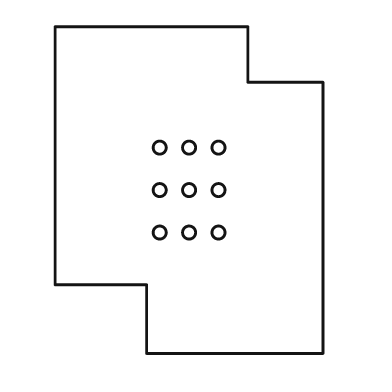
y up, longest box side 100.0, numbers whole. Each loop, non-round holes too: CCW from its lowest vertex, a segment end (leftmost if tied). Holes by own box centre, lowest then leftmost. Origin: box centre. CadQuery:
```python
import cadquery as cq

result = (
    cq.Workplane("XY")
    .moveTo(-13.0, -50.0)
    .lineTo(41.0, -50.0)
    .lineTo(41.0, 33.0)
    .lineTo(18.0, 33.0)
    .lineTo(18.0, 50.0)
    .lineTo(-41.0, 50.0)
    .lineTo(-41.0, -29.0)
    .lineTo(-13.0, -29.0)
    .close()
    .moveTo(-9.0, -13.0)
    .circle(2.0)
    .moveTo(0.0, -13.0)
    .circle(2.0)
    .moveTo(9.0, -13.0)
    .circle(2.0)
    .moveTo(-9.0, 0.0)
    .circle(2.0)
    .moveTo(0.0, 0.0)
    .circle(2.0)
    .moveTo(9.0, 0.0)
    .circle(2.0)
    .moveTo(-9.0, 13.0)
    .circle(2.0)
    .moveTo(0.0, 13.0)
    .circle(2.0)
    .moveTo(9.0, 13.0)
    .circle(2.0)
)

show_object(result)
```